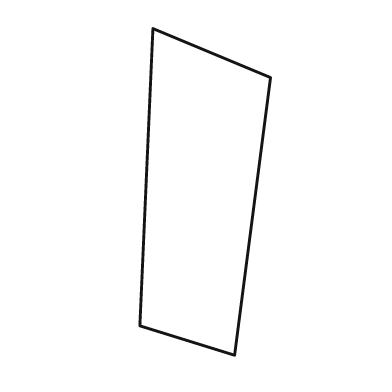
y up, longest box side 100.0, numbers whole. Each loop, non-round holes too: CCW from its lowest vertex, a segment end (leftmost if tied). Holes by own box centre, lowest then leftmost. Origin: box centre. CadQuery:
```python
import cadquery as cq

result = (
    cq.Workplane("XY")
    .moveTo(9.0, -50.0)
    .lineTo(20.0, 35.0)
    .lineTo(-16.0, 50.0)
    .lineTo(-20.0, -41.0)
    .close()
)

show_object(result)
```